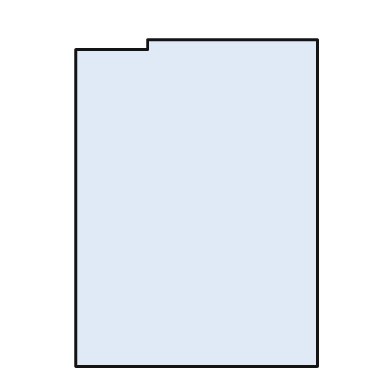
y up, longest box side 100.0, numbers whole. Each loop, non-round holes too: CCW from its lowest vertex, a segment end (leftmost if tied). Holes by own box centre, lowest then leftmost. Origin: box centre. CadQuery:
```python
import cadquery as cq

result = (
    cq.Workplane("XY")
    .moveTo(-37.0, -50.0)
    .lineTo(37.0, -50.0)
    .lineTo(37.0, 50.0)
    .lineTo(-15.0, 50.0)
    .lineTo(-15.0, 47.0)
    .lineTo(-37.0, 47.0)
    .close()
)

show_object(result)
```